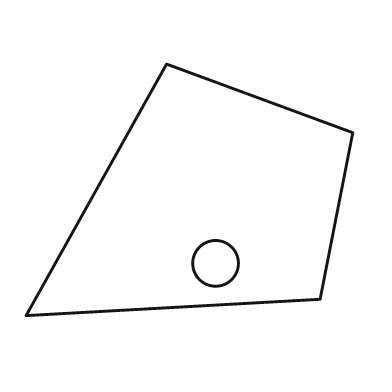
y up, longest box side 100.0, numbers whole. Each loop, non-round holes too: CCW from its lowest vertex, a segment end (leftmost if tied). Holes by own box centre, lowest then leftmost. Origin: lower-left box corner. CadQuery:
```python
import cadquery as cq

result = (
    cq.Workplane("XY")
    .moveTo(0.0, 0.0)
    .lineTo(90.0, 5.0)
    .lineTo(100.0, 56.0)
    .lineTo(43.0, 77.0)
    .close()
    .moveTo(58.0, 16.0)
    .circle(7.0)
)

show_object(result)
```